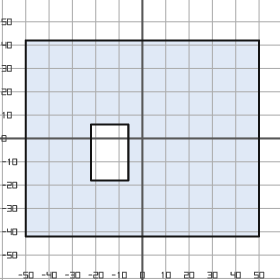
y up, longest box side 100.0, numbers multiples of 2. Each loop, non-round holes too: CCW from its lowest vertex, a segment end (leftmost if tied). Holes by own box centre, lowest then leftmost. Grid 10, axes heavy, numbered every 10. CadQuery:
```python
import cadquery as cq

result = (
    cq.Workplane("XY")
    .moveTo(-50.0, -42.0)
    .lineTo(50.0, -42.0)
    .lineTo(50.0, 42.0)
    .lineTo(-50.0, 42.0)
    .close()
    .moveTo(-22.0, -18.0)
    .lineTo(-6.0, -18.0)
    .lineTo(-6.0, 6.0)
    .lineTo(-22.0, 6.0)
    .close()
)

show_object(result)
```